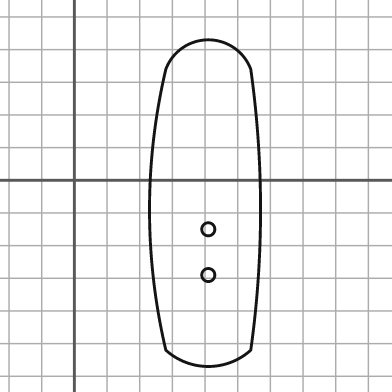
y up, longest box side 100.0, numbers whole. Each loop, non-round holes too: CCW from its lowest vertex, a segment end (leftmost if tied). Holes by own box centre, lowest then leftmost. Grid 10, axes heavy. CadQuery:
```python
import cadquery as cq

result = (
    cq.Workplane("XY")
    .moveTo(28.0, -52.0)
    .threePointArc((41.0, -57.0), (54.0, -52.0))
    .threePointArc((57.0, -9.0), (54.0, 34.0))
    .threePointArc((41.0, 43.0), (28.0, 34.0))
    .threePointArc((23.0, -9.0), (28.0, -52.0))
    .close()
    .moveTo(41.0, -29.0)
    .circle(2.0)
    .moveTo(41.0, -15.0)
    .circle(2.0)
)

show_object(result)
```